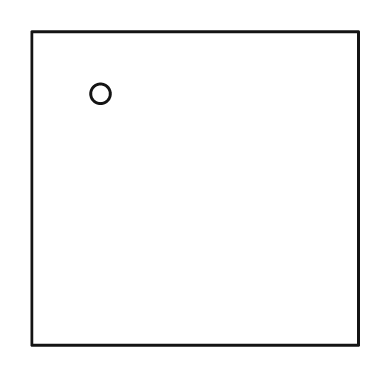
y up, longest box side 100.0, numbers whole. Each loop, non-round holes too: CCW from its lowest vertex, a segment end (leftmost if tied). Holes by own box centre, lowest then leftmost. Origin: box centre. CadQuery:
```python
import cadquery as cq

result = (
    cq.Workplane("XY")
    .moveTo(-50.0, -48.0)
    .lineTo(50.0, -48.0)
    .lineTo(50.0, 48.0)
    .lineTo(-50.0, 48.0)
    .close()
    .moveTo(-29.0, 29.0)
    .circle(3.0)
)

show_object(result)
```